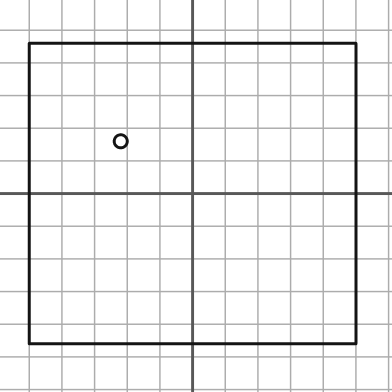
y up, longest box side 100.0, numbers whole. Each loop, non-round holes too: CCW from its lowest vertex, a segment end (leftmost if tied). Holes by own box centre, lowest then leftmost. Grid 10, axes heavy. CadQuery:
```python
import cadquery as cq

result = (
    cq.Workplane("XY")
    .moveTo(-50.0, -46.0)
    .lineTo(50.0, -46.0)
    .lineTo(50.0, 46.0)
    .lineTo(-50.0, 46.0)
    .close()
    .moveTo(-22.0, 16.0)
    .circle(2.0)
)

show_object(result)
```